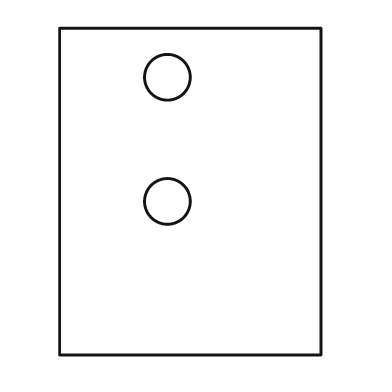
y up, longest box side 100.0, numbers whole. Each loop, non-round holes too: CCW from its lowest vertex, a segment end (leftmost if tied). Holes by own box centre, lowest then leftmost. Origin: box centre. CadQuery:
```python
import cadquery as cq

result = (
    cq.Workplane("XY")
    .moveTo(-40.0, -50.0)
    .lineTo(40.0, -50.0)
    .lineTo(40.0, 50.0)
    .lineTo(-40.0, 50.0)
    .close()
    .moveTo(-7.0, -3.0)
    .circle(7.0)
    .moveTo(-7.0, 35.0)
    .circle(7.0)
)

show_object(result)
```